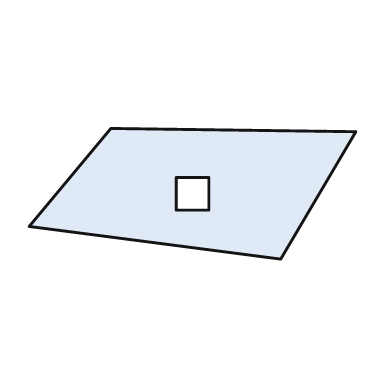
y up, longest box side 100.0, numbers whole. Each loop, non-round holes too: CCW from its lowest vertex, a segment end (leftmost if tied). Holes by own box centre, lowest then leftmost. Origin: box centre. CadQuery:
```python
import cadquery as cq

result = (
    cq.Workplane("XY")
    .moveTo(27.0, -20.0)
    .lineTo(50.0, 19.0)
    .lineTo(-25.0, 20.0)
    .lineTo(-50.0, -10.0)
    .close()
    .moveTo(-5.0, -5.0)
    .lineTo(5.0, -5.0)
    .lineTo(5.0, 5.0)
    .lineTo(-5.0, 5.0)
    .close()
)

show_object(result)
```